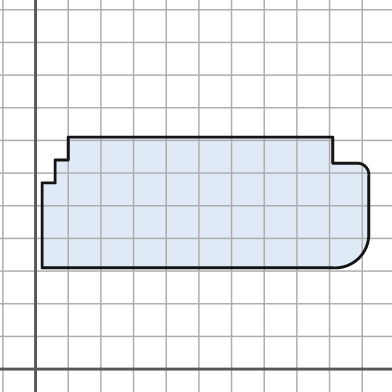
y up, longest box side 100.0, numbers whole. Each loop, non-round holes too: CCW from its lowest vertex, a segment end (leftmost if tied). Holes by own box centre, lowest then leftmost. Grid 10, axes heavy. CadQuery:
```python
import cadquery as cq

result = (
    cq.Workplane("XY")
    .moveTo(2.0, 31.0)
    .lineTo(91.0, 31.0)
    .threePointArc((99.0, 34.0), (102.0, 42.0))
    .lineTo(102.0, 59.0)
    .threePointArc((101.0, 62.0), (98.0, 63.0))
    .lineTo(91.0, 63.0)
    .lineTo(91.0, 71.0)
    .lineTo(10.0, 71.0)
    .lineTo(10.0, 64.0)
    .lineTo(6.0, 64.0)
    .lineTo(6.0, 57.0)
    .lineTo(2.0, 57.0)
    .close()
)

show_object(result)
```